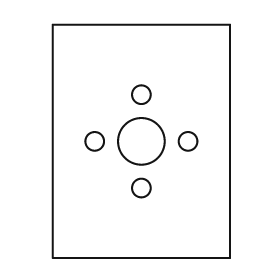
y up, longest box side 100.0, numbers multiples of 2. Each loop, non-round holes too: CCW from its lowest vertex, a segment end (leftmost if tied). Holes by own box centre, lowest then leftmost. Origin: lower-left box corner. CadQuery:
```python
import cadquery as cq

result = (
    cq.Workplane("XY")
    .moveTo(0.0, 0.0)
    .lineTo(76.0, 0.0)
    .lineTo(76.0, 100.0)
    .lineTo(0.0, 100.0)
    .close()
    .moveTo(38.0, 30.0)
    .circle(4.0)
    .moveTo(18.0, 50.0)
    .circle(4.0)
    .moveTo(38.0, 50.0)
    .circle(10.0)
    .moveTo(58.0, 50.0)
    .circle(4.0)
    .moveTo(38.0, 70.0)
    .circle(4.0)
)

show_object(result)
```